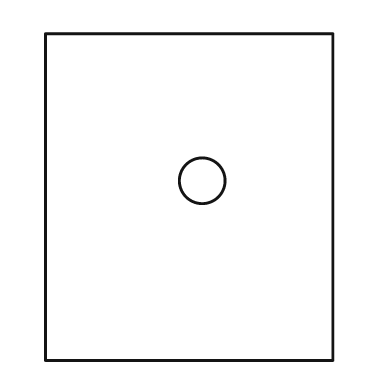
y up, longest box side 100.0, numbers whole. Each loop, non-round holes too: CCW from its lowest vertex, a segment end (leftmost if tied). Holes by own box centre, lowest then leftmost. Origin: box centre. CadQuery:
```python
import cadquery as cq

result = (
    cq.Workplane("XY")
    .moveTo(-44.0, -50.0)
    .lineTo(44.0, -50.0)
    .lineTo(44.0, 50.0)
    .lineTo(-44.0, 50.0)
    .close()
    .moveTo(4.0, 5.0)
    .circle(7.0)
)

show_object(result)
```